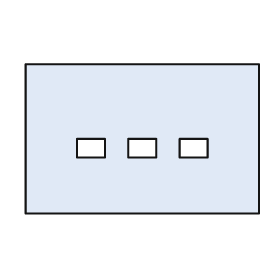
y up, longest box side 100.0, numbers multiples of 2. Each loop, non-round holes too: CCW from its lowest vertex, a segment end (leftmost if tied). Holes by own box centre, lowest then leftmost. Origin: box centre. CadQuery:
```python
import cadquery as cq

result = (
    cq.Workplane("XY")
    .moveTo(-50.0, -32.0)
    .lineTo(50.0, -32.0)
    .lineTo(50.0, 32.0)
    .lineTo(-50.0, 32.0)
    .close()
    .moveTo(-28.0, -8.0)
    .lineTo(-16.0, -8.0)
    .lineTo(-16.0, 0.0)
    .lineTo(-28.0, 0.0)
    .close()
    .moveTo(-6.0, -8.0)
    .lineTo(6.0, -8.0)
    .lineTo(6.0, 0.0)
    .lineTo(-6.0, 0.0)
    .close()
    .moveTo(16.0, -8.0)
    .lineTo(28.0, -8.0)
    .lineTo(28.0, 0.0)
    .lineTo(16.0, 0.0)
    .close()
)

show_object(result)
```